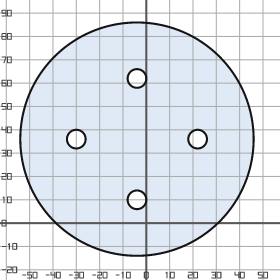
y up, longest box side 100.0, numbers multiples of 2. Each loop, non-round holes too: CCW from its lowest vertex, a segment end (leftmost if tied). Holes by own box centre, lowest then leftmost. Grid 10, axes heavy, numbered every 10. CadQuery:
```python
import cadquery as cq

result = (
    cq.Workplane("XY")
    .moveTo(-4.0, 36.0)
    .circle(50.0)
    .moveTo(-4.0, 10.0)
    .circle(4.0)
    .moveTo(-30.0, 36.0)
    .circle(4.0)
    .moveTo(22.0, 36.0)
    .circle(4.0)
    .moveTo(-4.0, 62.0)
    .circle(4.0)
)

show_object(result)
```